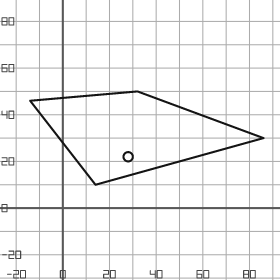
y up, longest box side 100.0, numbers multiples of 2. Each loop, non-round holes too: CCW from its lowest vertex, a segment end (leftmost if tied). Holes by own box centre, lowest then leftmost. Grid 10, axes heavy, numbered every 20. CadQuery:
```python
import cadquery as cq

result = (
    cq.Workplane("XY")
    .moveTo(14.0, 10.0)
    .lineTo(86.0, 30.0)
    .lineTo(32.0, 50.0)
    .lineTo(-14.0, 46.0)
    .close()
    .moveTo(28.0, 22.0)
    .circle(2.0)
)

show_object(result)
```